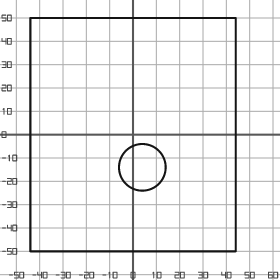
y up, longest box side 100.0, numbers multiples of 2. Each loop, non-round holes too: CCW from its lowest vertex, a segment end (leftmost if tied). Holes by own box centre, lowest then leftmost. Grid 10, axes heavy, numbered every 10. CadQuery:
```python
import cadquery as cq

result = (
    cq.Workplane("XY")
    .moveTo(-44.0, -50.0)
    .lineTo(44.0, -50.0)
    .lineTo(44.0, 50.0)
    .lineTo(-44.0, 50.0)
    .close()
    .moveTo(4.0, -14.0)
    .circle(10.0)
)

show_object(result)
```